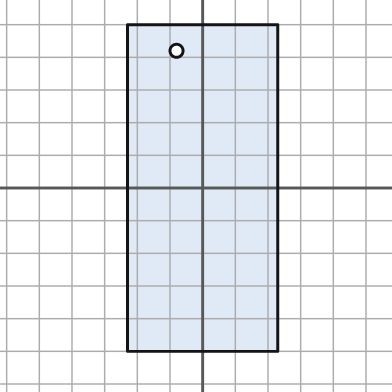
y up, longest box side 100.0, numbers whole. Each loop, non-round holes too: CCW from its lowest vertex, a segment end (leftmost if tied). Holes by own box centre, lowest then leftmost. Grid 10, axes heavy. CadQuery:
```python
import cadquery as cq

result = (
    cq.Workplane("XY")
    .moveTo(-23.0, -50.0)
    .lineTo(23.0, -50.0)
    .lineTo(23.0, 50.0)
    .lineTo(-23.0, 50.0)
    .close()
    .moveTo(-8.0, 42.0)
    .circle(2.0)
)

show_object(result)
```